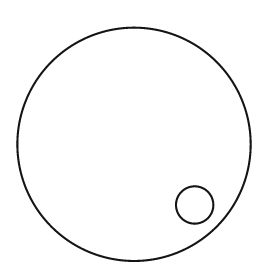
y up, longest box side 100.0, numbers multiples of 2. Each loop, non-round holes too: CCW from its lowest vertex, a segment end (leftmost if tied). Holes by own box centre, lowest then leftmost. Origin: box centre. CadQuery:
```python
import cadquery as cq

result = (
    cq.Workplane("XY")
    .moveTo(0.0, 0.0)
    .circle(50.0)
    .moveTo(26.0, -26.0)
    .circle(8.0)
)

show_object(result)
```